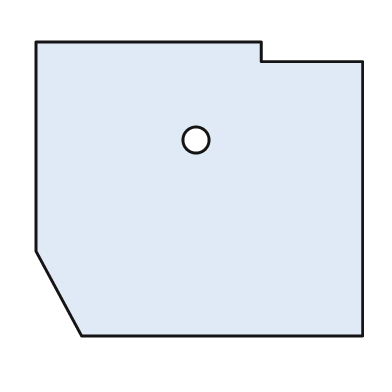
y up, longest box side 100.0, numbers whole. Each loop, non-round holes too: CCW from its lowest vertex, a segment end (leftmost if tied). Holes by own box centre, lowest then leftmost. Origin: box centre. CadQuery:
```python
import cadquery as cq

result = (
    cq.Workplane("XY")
    .moveTo(-36.0, -45.0)
    .lineTo(50.0, -45.0)
    .lineTo(50.0, 39.0)
    .lineTo(19.0, 39.0)
    .lineTo(19.0, 45.0)
    .lineTo(-50.0, 45.0)
    .lineTo(-50.0, -19.0)
    .close()
    .moveTo(-1.0, 15.0)
    .circle(4.0)
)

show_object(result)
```